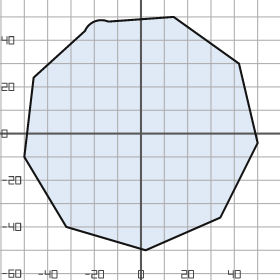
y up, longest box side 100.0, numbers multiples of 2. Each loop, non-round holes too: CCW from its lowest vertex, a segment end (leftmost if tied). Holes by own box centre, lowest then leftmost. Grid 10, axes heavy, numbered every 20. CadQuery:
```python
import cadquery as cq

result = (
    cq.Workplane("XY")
    .moveTo(2.0, -50.0)
    .lineTo(34.0, -36.0)
    .lineTo(50.0, -4.0)
    .lineTo(42.0, 30.0)
    .lineTo(14.0, 50.0)
    .lineTo(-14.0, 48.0)
    .threePointArc((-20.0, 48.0), (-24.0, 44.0))
    .lineTo(-46.0, 24.0)
    .lineTo(-50.0, -10.0)
    .lineTo(-32.0, -40.0)
    .close()
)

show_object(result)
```